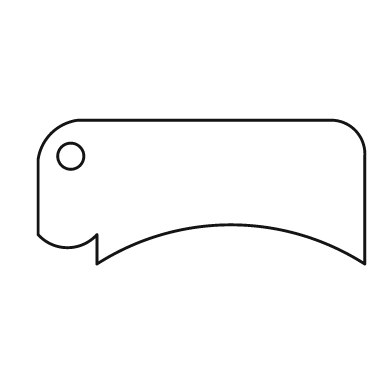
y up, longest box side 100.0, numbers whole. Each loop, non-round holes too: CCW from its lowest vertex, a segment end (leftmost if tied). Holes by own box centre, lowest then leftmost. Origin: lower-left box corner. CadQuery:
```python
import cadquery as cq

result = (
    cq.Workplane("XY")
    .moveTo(18.0, 0.0)
    .threePointArc((59.0, 12.0), (100.0, 0.0))
    .lineTo(100.0, 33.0)
    .threePointArc((97.0, 41.0), (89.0, 44.0))
    .lineTo(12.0, 44.0)
    .threePointArc((4.0, 40.0), (0.0, 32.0))
    .lineTo(0.0, 9.0)
    .threePointArc((9.0, 5.0), (18.0, 9.0))
    .close()
    .moveTo(10.0, 33.0)
    .circle(4.0)
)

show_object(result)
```